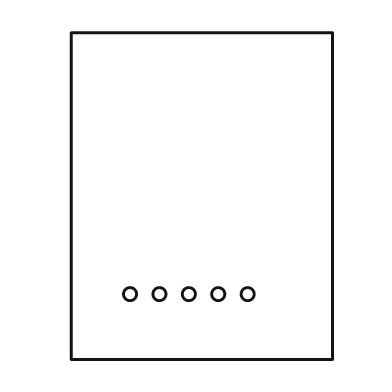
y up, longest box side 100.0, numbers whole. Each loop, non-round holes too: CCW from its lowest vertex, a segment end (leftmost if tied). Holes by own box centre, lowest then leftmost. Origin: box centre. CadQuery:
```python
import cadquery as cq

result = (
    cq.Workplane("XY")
    .moveTo(-40.0, -50.0)
    .lineTo(40.0, -50.0)
    .lineTo(40.0, 50.0)
    .lineTo(-40.0, 50.0)
    .close()
    .moveTo(-22.0, -30.0)
    .circle(2.0)
    .moveTo(-13.0, -30.0)
    .circle(2.0)
    .moveTo(-4.0, -30.0)
    .circle(2.0)
    .moveTo(5.0, -30.0)
    .circle(2.0)
    .moveTo(14.0, -30.0)
    .circle(2.0)
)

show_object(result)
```